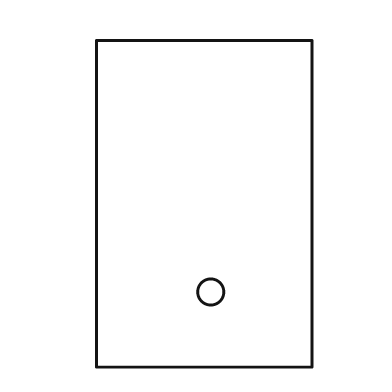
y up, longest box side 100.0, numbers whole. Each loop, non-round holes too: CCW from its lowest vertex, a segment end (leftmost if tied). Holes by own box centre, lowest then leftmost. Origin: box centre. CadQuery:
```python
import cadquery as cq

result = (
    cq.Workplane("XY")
    .moveTo(-33.0, -50.0)
    .lineTo(33.0, -50.0)
    .lineTo(33.0, 50.0)
    .lineTo(-33.0, 50.0)
    .close()
    .moveTo(2.0, -27.0)
    .circle(4.0)
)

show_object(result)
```